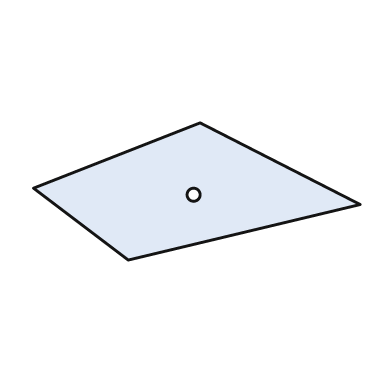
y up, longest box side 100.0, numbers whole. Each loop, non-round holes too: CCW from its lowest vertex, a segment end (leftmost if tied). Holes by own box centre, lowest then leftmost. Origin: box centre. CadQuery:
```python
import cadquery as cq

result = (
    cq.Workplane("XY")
    .moveTo(-21.0, -21.0)
    .lineTo(50.0, -4.0)
    .lineTo(1.0, 21.0)
    .lineTo(-50.0, 1.0)
    .close()
    .moveTo(-1.0, -1.0)
    .circle(2.0)
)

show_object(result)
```